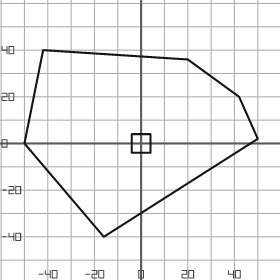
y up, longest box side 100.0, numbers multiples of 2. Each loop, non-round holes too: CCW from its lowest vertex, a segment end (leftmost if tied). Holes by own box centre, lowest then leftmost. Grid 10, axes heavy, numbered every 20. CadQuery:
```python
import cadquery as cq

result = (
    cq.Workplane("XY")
    .moveTo(-16.0, -40.0)
    .lineTo(50.0, 2.0)
    .lineTo(42.0, 20.0)
    .lineTo(20.0, 36.0)
    .lineTo(-42.0, 40.0)
    .lineTo(-50.0, 0.0)
    .close()
    .moveTo(-4.0, -4.0)
    .lineTo(4.0, -4.0)
    .lineTo(4.0, 4.0)
    .lineTo(-4.0, 4.0)
    .close()
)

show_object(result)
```